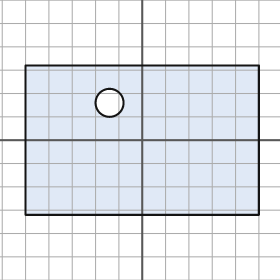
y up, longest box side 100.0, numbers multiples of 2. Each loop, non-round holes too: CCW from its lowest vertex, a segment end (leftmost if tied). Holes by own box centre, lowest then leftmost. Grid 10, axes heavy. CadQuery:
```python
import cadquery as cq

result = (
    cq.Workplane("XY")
    .moveTo(-50.0, -32.0)
    .lineTo(50.0, -32.0)
    .lineTo(50.0, 32.0)
    .lineTo(-50.0, 32.0)
    .close()
    .moveTo(-14.0, 16.0)
    .circle(6.0)
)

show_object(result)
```